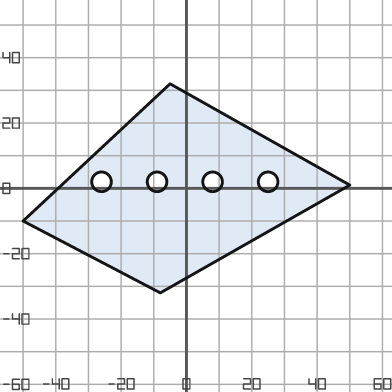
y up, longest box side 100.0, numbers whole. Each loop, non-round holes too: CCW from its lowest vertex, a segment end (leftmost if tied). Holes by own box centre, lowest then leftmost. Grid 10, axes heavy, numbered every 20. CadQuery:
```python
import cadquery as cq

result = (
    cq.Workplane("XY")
    .moveTo(-8.0, -32.0)
    .lineTo(50.0, 1.0)
    .lineTo(-5.0, 32.0)
    .lineTo(-50.0, -10.0)
    .close()
    .moveTo(-26.0, 2.0)
    .circle(3.0)
    .moveTo(-9.0, 2.0)
    .circle(3.0)
    .moveTo(8.0, 2.0)
    .circle(3.0)
    .moveTo(25.0, 2.0)
    .circle(3.0)
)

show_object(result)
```